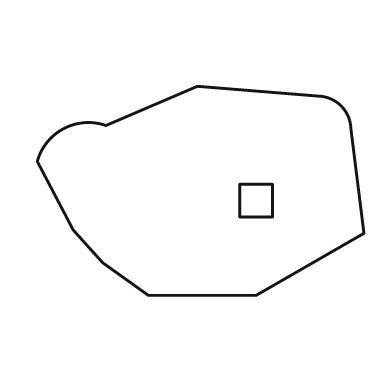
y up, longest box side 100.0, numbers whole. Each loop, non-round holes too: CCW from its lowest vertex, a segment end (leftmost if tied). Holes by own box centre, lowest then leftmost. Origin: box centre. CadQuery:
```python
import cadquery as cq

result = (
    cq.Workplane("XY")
    .moveTo(-16.0, -32.0)
    .lineTo(17.0, -32.0)
    .lineTo(50.0, -13.0)
    .lineTo(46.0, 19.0)
    .threePointArc((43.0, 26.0), (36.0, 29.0))
    .lineTo(-1.0, 32.0)
    .lineTo(-29.0, 20.0)
    .threePointArc((-42.0, 19.0), (-50.0, 9.0))
    .lineTo(-39.0, -12.0)
    .lineTo(-30.0, -22.0)
    .close()
    .moveTo(12.0, -8.0)
    .lineTo(22.0, -8.0)
    .lineTo(22.0, 2.0)
    .lineTo(12.0, 2.0)
    .close()
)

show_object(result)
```